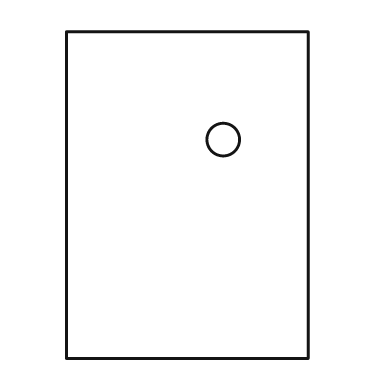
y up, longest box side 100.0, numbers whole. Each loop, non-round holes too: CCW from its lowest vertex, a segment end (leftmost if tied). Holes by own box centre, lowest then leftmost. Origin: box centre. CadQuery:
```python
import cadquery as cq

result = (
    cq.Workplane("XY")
    .moveTo(-37.0, -50.0)
    .lineTo(37.0, -50.0)
    .lineTo(37.0, 50.0)
    .lineTo(-37.0, 50.0)
    .close()
    .moveTo(11.0, 17.0)
    .circle(5.0)
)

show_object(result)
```